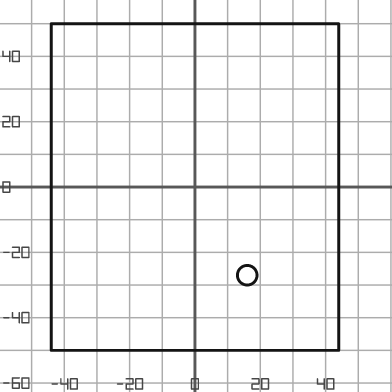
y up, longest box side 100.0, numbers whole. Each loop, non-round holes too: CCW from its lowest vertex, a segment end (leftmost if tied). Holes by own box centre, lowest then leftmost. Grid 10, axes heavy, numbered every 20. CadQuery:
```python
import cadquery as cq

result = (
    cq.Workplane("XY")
    .moveTo(-44.0, -50.0)
    .lineTo(44.0, -50.0)
    .lineTo(44.0, 50.0)
    .lineTo(-44.0, 50.0)
    .close()
    .moveTo(16.0, -27.0)
    .circle(3.0)
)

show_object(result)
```